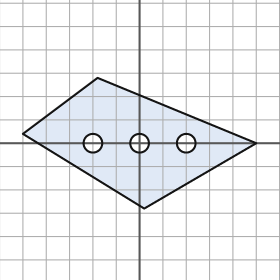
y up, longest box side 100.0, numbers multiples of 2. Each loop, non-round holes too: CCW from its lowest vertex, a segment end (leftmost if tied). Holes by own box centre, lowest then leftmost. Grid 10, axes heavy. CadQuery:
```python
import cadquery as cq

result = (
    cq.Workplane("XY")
    .moveTo(2.0, -28.0)
    .lineTo(50.0, 0.0)
    .lineTo(-18.0, 28.0)
    .lineTo(-50.0, 4.0)
    .close()
    .moveTo(-20.0, 0.0)
    .circle(4.0)
    .moveTo(0.0, 0.0)
    .circle(4.0)
    .moveTo(20.0, 0.0)
    .circle(4.0)
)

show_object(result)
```